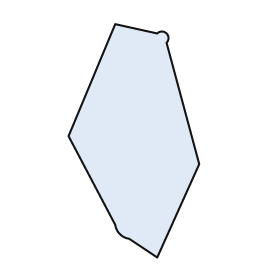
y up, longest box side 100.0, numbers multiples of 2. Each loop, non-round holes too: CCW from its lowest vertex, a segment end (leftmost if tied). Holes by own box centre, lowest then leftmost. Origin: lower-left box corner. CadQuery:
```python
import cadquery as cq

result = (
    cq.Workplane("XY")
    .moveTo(38.0, 0.0)
    .lineTo(56.0, 40.0)
    .lineTo(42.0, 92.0)
    .threePointArc((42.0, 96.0), (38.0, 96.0))
    .lineTo(20.0, 100.0)
    .lineTo(0.0, 52.0)
    .lineTo(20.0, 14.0)
    .threePointArc((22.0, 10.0), (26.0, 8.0))
    .close()
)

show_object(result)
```